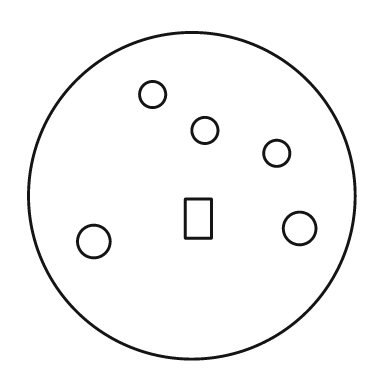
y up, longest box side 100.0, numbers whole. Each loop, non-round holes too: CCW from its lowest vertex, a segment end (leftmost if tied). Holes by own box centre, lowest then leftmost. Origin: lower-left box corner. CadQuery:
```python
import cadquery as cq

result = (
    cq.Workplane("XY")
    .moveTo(50.0, 50.0)
    .circle(50.0)
    .moveTo(20.0, 36.0)
    .circle(5.0)
    .moveTo(83.0, 40.0)
    .circle(5.0)
    .moveTo(48.0, 37.0)
    .lineTo(56.0, 37.0)
    .lineTo(56.0, 49.0)
    .lineTo(48.0, 49.0)
    .close()
    .moveTo(76.0, 63.0)
    .circle(4.0)
    .moveTo(54.0, 70.0)
    .circle(4.0)
    .moveTo(38.0, 81.0)
    .circle(4.0)
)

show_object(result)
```